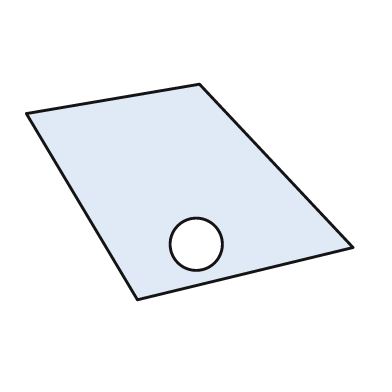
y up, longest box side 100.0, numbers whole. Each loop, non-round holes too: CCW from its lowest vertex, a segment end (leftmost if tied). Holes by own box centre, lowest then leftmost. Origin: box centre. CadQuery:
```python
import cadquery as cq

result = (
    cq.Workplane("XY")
    .moveTo(-16.0, -33.0)
    .lineTo(50.0, -17.0)
    .lineTo(3.0, 33.0)
    .lineTo(-50.0, 24.0)
    .close()
    .moveTo(2.0, -16.0)
    .circle(8.0)
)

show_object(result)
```